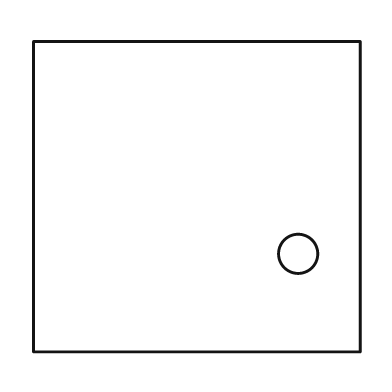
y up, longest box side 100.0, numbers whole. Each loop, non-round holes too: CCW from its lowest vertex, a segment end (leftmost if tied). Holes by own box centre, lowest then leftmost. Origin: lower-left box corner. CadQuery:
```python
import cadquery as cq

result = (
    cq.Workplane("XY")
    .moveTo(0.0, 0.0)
    .lineTo(100.0, 0.0)
    .lineTo(100.0, 95.0)
    .lineTo(0.0, 95.0)
    .close()
    .moveTo(81.0, 30.0)
    .circle(6.0)
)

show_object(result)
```